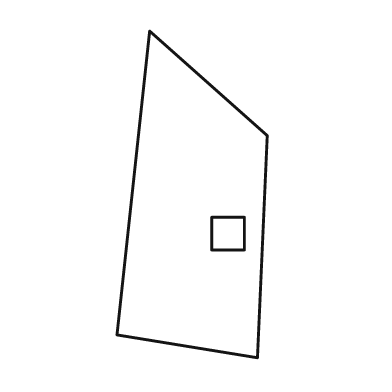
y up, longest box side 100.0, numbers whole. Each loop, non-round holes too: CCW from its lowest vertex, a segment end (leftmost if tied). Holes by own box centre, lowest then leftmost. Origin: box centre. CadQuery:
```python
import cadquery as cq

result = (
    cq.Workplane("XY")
    .moveTo(20.0, -50.0)
    .lineTo(23.0, 18.0)
    .lineTo(-13.0, 50.0)
    .lineTo(-23.0, -43.0)
    .close()
    .moveTo(6.0, -17.0)
    .lineTo(16.0, -17.0)
    .lineTo(16.0, -7.0)
    .lineTo(6.0, -7.0)
    .close()
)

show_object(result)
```